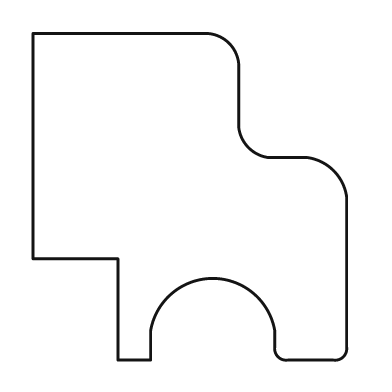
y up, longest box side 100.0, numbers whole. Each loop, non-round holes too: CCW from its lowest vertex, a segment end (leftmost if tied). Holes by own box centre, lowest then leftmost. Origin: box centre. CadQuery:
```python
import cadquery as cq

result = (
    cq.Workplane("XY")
    .moveTo(-22.0, -50.0)
    .lineTo(-12.0, -50.0)
    .lineTo(-12.0, -41.0)
    .threePointArc((7.0, -25.0), (26.0, -41.0))
    .lineTo(26.0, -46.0)
    .threePointArc((27.0, -49.0), (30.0, -50.0))
    .lineTo(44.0, -50.0)
    .threePointArc((47.0, -49.0), (48.0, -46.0))
    .lineTo(48.0, 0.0)
    .threePointArc((44.0, 8.0), (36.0, 12.0))
    .lineTo(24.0, 12.0)
    .threePointArc((18.0, 15.0), (15.0, 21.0))
    .lineTo(15.0, 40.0)
    .threePointArc((12.0, 47.0), (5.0, 50.0))
    .lineTo(-48.0, 50.0)
    .lineTo(-48.0, -19.0)
    .lineTo(-22.0, -19.0)
    .close()
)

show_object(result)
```